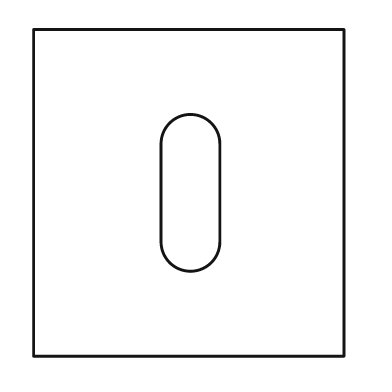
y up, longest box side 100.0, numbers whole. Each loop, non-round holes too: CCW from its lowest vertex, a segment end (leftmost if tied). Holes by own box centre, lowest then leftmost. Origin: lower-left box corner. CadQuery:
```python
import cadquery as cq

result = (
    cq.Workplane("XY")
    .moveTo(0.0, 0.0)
    .lineTo(95.0, 0.0)
    .lineTo(95.0, 100.0)
    .lineTo(0.0, 100.0)
    .close()
    .moveTo(39.0, 35.0)
    .threePointArc((48.0, 26.0), (57.0, 35.0))
    .lineTo(57.0, 65.0)
    .threePointArc((48.0, 74.0), (39.0, 65.0))
    .close()
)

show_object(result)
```